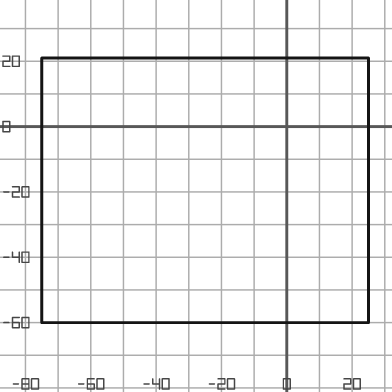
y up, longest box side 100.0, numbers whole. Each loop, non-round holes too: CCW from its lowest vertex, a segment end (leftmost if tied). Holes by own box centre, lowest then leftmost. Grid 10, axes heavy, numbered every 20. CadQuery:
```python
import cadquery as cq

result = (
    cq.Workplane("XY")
    .moveTo(-75.0, -60.0)
    .lineTo(25.0, -60.0)
    .lineTo(25.0, 21.0)
    .lineTo(-75.0, 21.0)
    .close()
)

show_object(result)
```